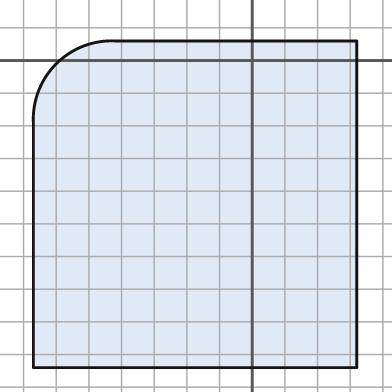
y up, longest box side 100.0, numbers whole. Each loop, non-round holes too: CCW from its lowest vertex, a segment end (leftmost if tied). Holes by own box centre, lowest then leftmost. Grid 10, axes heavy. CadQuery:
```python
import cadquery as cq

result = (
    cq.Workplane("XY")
    .moveTo(-67.0, -94.0)
    .lineTo(32.0, -94.0)
    .lineTo(32.0, 6.0)
    .lineTo(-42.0, 6.0)
    .threePointArc((-60.0, -1.0), (-67.0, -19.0))
    .close()
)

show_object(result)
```